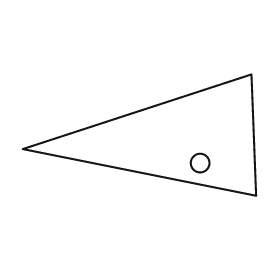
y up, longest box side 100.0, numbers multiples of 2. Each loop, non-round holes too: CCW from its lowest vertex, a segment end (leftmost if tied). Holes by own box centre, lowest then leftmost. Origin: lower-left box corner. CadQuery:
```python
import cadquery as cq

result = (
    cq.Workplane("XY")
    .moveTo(100.0, 0.0)
    .lineTo(98.0, 52.0)
    .lineTo(0.0, 20.0)
    .close()
    .moveTo(76.0, 14.0)
    .circle(4.0)
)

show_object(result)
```